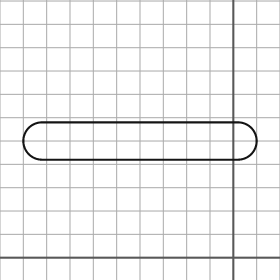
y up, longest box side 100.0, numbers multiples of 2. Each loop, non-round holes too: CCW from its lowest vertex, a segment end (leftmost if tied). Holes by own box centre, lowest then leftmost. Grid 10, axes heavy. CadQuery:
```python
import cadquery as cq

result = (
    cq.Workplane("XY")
    .moveTo(-82.0, 42.0)
    .lineTo(2.0, 42.0)
    .threePointArc((10.0, 50.0), (2.0, 58.0))
    .lineTo(-82.0, 58.0)
    .threePointArc((-90.0, 50.0), (-82.0, 42.0))
    .close()
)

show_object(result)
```